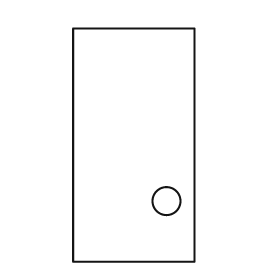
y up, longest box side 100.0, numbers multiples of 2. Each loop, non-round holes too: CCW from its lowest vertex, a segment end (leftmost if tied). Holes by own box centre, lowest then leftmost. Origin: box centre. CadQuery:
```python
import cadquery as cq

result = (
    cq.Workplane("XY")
    .moveTo(-26.0, -50.0)
    .lineTo(26.0, -50.0)
    .lineTo(26.0, 50.0)
    .lineTo(-26.0, 50.0)
    .close()
    .moveTo(14.0, -24.0)
    .circle(6.0)
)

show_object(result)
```